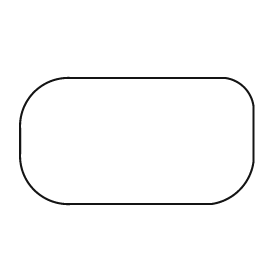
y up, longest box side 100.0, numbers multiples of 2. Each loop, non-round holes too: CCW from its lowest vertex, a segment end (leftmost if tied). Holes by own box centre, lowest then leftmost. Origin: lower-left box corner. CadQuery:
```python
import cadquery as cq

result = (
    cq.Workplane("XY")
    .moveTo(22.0, 0.0)
    .lineTo(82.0, 0.0)
    .threePointArc((94.0, 6.0), (100.0, 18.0))
    .lineTo(100.0, 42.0)
    .threePointArc((96.0, 50.0), (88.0, 54.0))
    .lineTo(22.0, 54.0)
    .threePointArc((6.0, 48.0), (0.0, 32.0))
    .lineTo(0.0, 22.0)
    .threePointArc((6.0, 6.0), (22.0, 0.0))
    .close()
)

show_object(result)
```